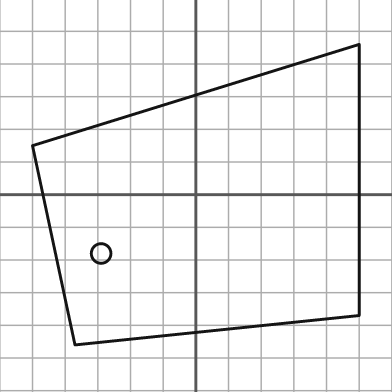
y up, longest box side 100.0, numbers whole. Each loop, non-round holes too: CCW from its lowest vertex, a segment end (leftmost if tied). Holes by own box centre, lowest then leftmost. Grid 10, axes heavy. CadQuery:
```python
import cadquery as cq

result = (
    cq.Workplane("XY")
    .moveTo(-37.0, -46.0)
    .lineTo(50.0, -37.0)
    .lineTo(50.0, 46.0)
    .lineTo(-50.0, 15.0)
    .close()
    .moveTo(-29.0, -18.0)
    .circle(3.0)
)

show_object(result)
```